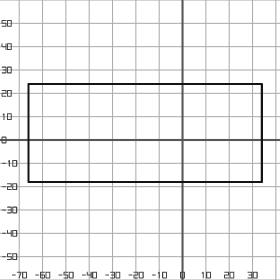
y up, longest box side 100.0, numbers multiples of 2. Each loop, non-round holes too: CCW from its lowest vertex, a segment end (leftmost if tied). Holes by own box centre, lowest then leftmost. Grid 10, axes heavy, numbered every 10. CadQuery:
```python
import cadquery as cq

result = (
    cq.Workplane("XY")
    .moveTo(-66.0, -18.0)
    .lineTo(34.0, -18.0)
    .lineTo(34.0, 24.0)
    .lineTo(-66.0, 24.0)
    .close()
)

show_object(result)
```